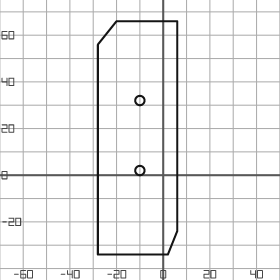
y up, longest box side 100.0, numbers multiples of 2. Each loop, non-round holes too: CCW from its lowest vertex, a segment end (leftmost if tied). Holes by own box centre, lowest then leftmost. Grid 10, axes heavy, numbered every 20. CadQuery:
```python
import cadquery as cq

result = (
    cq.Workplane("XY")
    .moveTo(-28.0, -34.0)
    .lineTo(2.0, -34.0)
    .lineTo(6.0, -24.0)
    .lineTo(6.0, 66.0)
    .lineTo(-20.0, 66.0)
    .lineTo(-28.0, 56.0)
    .close()
    .moveTo(-10.0, 2.0)
    .circle(2.0)
    .moveTo(-10.0, 32.0)
    .circle(2.0)
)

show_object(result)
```